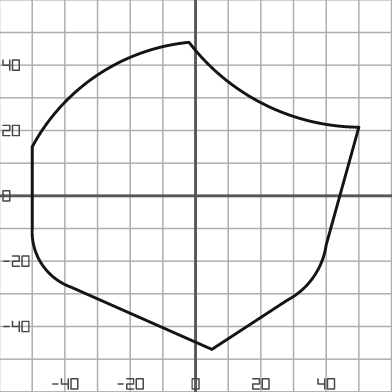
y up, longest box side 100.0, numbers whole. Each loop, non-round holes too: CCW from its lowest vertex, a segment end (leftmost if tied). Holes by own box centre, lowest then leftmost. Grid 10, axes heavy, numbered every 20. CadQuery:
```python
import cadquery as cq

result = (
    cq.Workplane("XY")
    .moveTo(5.0, -47.0)
    .lineTo(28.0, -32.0)
    .threePointArc((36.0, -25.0), (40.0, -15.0))
    .lineTo(50.0, 21.0)
    .threePointArc((21.0, 28.0), (-2.0, 47.0))
    .threePointArc((-30.0, 37.0), (-50.0, 15.0))
    .lineTo(-50.0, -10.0)
    .threePointArc((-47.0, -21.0), (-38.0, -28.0))
    .close()
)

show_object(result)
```